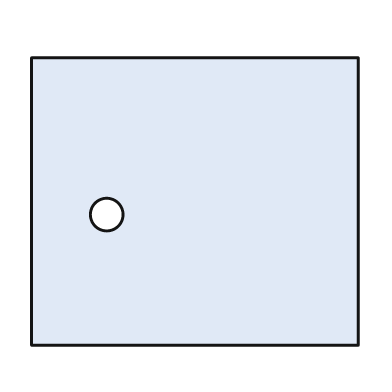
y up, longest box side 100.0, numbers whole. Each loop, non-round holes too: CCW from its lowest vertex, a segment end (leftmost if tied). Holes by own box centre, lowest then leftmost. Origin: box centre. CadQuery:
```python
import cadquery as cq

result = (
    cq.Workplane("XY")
    .moveTo(-50.0, -44.0)
    .lineTo(50.0, -44.0)
    .lineTo(50.0, 44.0)
    .lineTo(-50.0, 44.0)
    .close()
    .moveTo(-27.0, -4.0)
    .circle(5.0)
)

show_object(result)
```